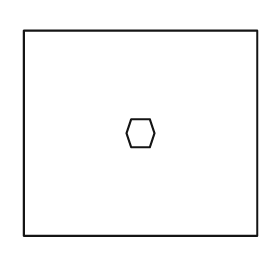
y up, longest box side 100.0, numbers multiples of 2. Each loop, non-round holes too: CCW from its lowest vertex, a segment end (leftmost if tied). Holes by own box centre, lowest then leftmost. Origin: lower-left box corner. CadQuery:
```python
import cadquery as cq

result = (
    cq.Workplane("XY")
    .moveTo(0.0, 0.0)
    .lineTo(100.0, 0.0)
    .lineTo(100.0, 88.0)
    .lineTo(0.0, 88.0)
    .close()
    .moveTo(46.0, 38.0)
    .lineTo(54.0, 38.0)
    .lineTo(56.0, 44.0)
    .lineTo(54.0, 50.0)
    .lineTo(46.0, 50.0)
    .lineTo(44.0, 44.0)
    .close()
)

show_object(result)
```